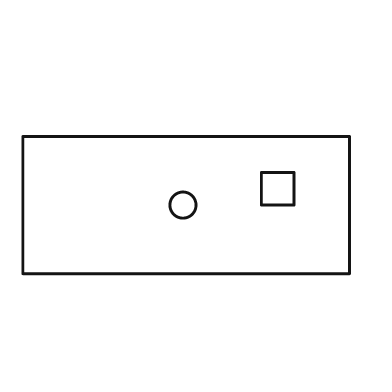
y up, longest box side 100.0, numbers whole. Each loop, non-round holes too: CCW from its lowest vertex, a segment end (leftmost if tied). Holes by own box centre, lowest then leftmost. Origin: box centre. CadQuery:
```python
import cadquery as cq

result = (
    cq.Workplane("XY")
    .moveTo(-50.0, -21.0)
    .lineTo(50.0, -21.0)
    .lineTo(50.0, 21.0)
    .lineTo(-50.0, 21.0)
    .close()
    .moveTo(-1.0, 0.0)
    .circle(4.0)
    .moveTo(23.0, 0.0)
    .lineTo(33.0, 0.0)
    .lineTo(33.0, 10.0)
    .lineTo(23.0, 10.0)
    .close()
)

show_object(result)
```